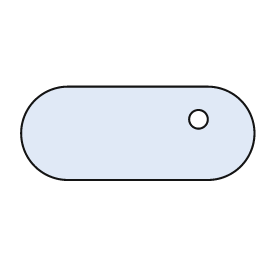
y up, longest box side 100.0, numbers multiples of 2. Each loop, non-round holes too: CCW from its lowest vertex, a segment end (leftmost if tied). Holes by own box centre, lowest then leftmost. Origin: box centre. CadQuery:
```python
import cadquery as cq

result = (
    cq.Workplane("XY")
    .moveTo(-30.0, -20.0)
    .lineTo(30.0, -20.0)
    .threePointArc((50.0, 0.0), (30.0, 20.0))
    .lineTo(-30.0, 20.0)
    .threePointArc((-50.0, 0.0), (-30.0, -20.0))
    .close()
    .moveTo(26.0, 6.0)
    .circle(4.0)
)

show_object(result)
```